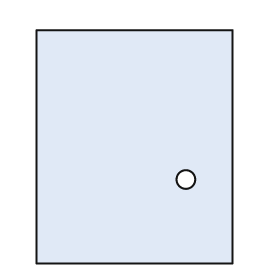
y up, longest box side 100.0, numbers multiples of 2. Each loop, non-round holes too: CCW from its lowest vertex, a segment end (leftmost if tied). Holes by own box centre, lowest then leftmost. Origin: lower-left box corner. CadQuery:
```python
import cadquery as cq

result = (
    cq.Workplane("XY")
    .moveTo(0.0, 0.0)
    .lineTo(84.0, 0.0)
    .lineTo(84.0, 100.0)
    .lineTo(0.0, 100.0)
    .close()
    .moveTo(64.0, 36.0)
    .circle(4.0)
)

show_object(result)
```